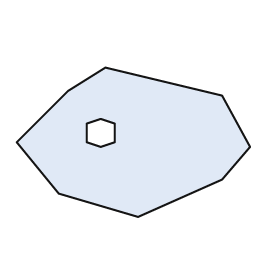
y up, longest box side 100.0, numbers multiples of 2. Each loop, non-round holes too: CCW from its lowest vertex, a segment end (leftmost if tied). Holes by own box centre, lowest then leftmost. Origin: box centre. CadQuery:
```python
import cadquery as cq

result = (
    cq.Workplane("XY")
    .moveTo(2.0, -32.0)
    .lineTo(38.0, -16.0)
    .lineTo(50.0, -2.0)
    .lineTo(38.0, 20.0)
    .lineTo(-12.0, 32.0)
    .lineTo(-28.0, 22.0)
    .lineTo(-50.0, 0.0)
    .lineTo(-32.0, -22.0)
    .close()
    .moveTo(-14.0, -2.0)
    .lineTo(-8.0, 0.0)
    .lineTo(-8.0, 8.0)
    .lineTo(-14.0, 10.0)
    .lineTo(-20.0, 8.0)
    .lineTo(-20.0, 0.0)
    .close()
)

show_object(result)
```